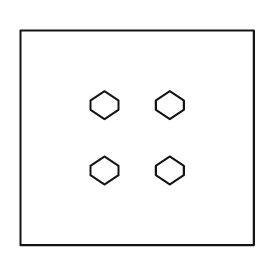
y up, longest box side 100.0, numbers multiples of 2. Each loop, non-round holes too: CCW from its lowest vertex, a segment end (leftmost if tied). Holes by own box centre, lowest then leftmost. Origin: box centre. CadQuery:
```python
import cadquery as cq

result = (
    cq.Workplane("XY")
    .moveTo(-50.0, -46.0)
    .lineTo(50.0, -46.0)
    .lineTo(50.0, 46.0)
    .lineTo(-50.0, 46.0)
    .close()
    .moveTo(-14.0, -20.0)
    .lineTo(-8.0, -16.0)
    .lineTo(-8.0, -12.0)
    .lineTo(-14.0, -8.0)
    .lineTo(-20.0, -12.0)
    .lineTo(-20.0, -16.0)
    .close()
    .moveTo(14.0, -20.0)
    .lineTo(20.0, -16.0)
    .lineTo(20.0, -12.0)
    .lineTo(14.0, -8.0)
    .lineTo(8.0, -12.0)
    .lineTo(8.0, -16.0)
    .close()
    .moveTo(-14.0, 8.0)
    .lineTo(-8.0, 12.0)
    .lineTo(-8.0, 16.0)
    .lineTo(-14.0, 20.0)
    .lineTo(-20.0, 16.0)
    .lineTo(-20.0, 12.0)
    .close()
    .moveTo(14.0, 8.0)
    .lineTo(20.0, 12.0)
    .lineTo(20.0, 16.0)
    .lineTo(14.0, 20.0)
    .lineTo(8.0, 16.0)
    .lineTo(8.0, 12.0)
    .close()
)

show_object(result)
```